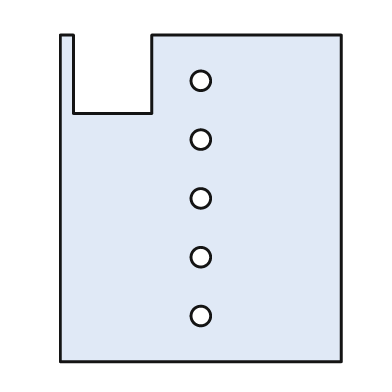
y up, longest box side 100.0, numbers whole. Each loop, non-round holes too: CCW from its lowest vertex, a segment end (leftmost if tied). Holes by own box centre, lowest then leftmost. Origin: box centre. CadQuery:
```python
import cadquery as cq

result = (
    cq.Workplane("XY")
    .moveTo(-43.0, -50.0)
    .lineTo(43.0, -50.0)
    .lineTo(43.0, 50.0)
    .lineTo(-15.0, 50.0)
    .lineTo(-15.0, 26.0)
    .lineTo(-39.0, 26.0)
    .lineTo(-39.0, 50.0)
    .lineTo(-43.0, 50.0)
    .close()
    .moveTo(0.0, -36.0)
    .circle(3.0)
    .moveTo(0.0, -18.0)
    .circle(3.0)
    .moveTo(0.0, 0.0)
    .circle(3.0)
    .moveTo(0.0, 18.0)
    .circle(3.0)
    .moveTo(0.0, 36.0)
    .circle(3.0)
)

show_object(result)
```